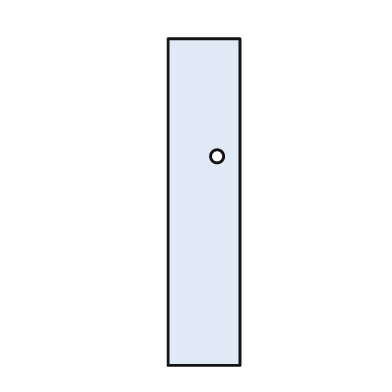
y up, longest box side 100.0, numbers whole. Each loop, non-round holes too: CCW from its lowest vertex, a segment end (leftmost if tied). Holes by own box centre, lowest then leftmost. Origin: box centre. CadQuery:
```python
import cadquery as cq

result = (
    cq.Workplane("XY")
    .moveTo(-11.0, -50.0)
    .lineTo(11.0, -50.0)
    .lineTo(11.0, 50.0)
    .lineTo(-11.0, 50.0)
    .close()
    .moveTo(4.0, 14.0)
    .circle(2.0)
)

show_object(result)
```